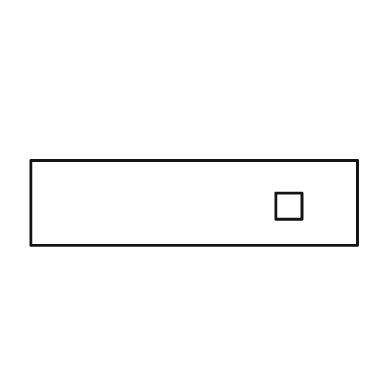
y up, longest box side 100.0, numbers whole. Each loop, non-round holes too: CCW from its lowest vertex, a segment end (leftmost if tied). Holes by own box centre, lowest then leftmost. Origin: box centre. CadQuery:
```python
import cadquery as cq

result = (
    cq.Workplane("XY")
    .moveTo(-50.0, -13.0)
    .lineTo(50.0, -13.0)
    .lineTo(50.0, 13.0)
    .lineTo(-50.0, 13.0)
    .close()
    .moveTo(25.0, -5.0)
    .lineTo(33.0, -5.0)
    .lineTo(33.0, 3.0)
    .lineTo(25.0, 3.0)
    .close()
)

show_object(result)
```